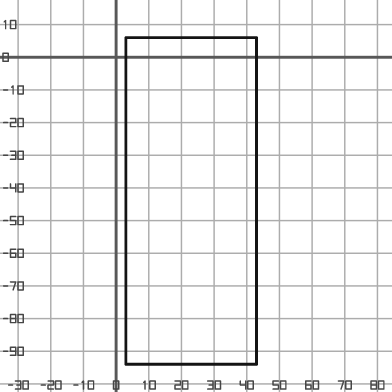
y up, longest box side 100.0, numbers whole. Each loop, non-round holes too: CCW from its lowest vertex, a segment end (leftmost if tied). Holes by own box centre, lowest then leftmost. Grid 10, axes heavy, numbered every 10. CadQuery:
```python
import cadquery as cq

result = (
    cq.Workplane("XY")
    .moveTo(3.0, -94.0)
    .lineTo(43.0, -94.0)
    .lineTo(43.0, 6.0)
    .lineTo(3.0, 6.0)
    .close()
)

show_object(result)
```